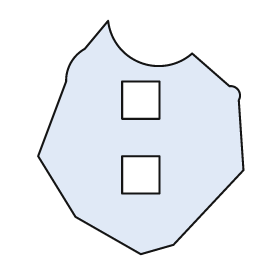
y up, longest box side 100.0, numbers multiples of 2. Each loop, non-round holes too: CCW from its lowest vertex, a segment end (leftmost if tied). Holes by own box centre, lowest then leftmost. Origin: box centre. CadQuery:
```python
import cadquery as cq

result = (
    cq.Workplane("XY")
    .moveTo(0.0, -50.0)
    .lineTo(14.0, -46.0)
    .lineTo(44.0, -14.0)
    .lineTo(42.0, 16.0)
    .threePointArc((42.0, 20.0), (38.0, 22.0))
    .lineTo(22.0, 36.0)
    .threePointArc((0.0, 32.0), (-14.0, 50.0))
    .lineTo(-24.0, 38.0)
    .threePointArc((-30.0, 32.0), (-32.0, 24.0))
    .lineTo(-44.0, -8.0)
    .lineTo(-28.0, -34.0)
    .close()
    .moveTo(-8.0, -24.0)
    .lineTo(8.0, -24.0)
    .lineTo(8.0, -8.0)
    .lineTo(-8.0, -8.0)
    .close()
    .moveTo(-8.0, 8.0)
    .lineTo(8.0, 8.0)
    .lineTo(8.0, 24.0)
    .lineTo(-8.0, 24.0)
    .close()
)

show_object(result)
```